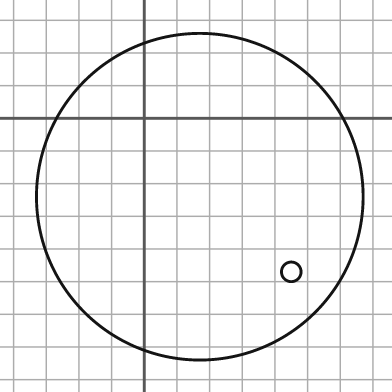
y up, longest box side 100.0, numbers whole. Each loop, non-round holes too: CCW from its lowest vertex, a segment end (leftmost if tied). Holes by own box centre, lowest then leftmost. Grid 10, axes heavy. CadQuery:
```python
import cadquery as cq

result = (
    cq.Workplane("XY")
    .moveTo(17.0, -24.0)
    .circle(50.0)
    .moveTo(45.0, -47.0)
    .circle(3.0)
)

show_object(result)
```